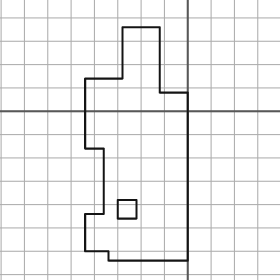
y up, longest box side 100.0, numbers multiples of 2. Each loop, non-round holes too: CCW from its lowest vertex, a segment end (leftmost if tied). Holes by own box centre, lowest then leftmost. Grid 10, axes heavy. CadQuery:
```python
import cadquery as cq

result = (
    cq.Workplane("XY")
    .moveTo(-34.0, -64.0)
    .lineTo(0.0, -64.0)
    .lineTo(0.0, 8.0)
    .lineTo(-12.0, 8.0)
    .lineTo(-12.0, 36.0)
    .lineTo(-28.0, 36.0)
    .lineTo(-28.0, 14.0)
    .lineTo(-44.0, 14.0)
    .lineTo(-44.0, -16.0)
    .lineTo(-36.0, -16.0)
    .lineTo(-36.0, -44.0)
    .lineTo(-44.0, -44.0)
    .lineTo(-44.0, -60.0)
    .lineTo(-34.0, -60.0)
    .close()
    .moveTo(-30.0, -46.0)
    .lineTo(-22.0, -46.0)
    .lineTo(-22.0, -38.0)
    .lineTo(-30.0, -38.0)
    .close()
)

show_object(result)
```